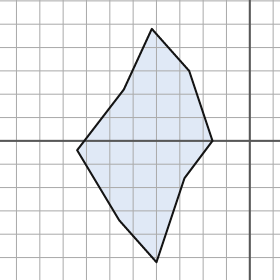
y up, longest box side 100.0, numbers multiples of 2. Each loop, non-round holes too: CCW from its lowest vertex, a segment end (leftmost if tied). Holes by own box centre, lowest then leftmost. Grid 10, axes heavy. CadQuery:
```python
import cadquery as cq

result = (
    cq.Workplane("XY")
    .moveTo(-40.0, -52.0)
    .lineTo(-28.0, -16.0)
    .lineTo(-16.0, 0.0)
    .lineTo(-26.0, 30.0)
    .lineTo(-42.0, 48.0)
    .lineTo(-54.0, 22.0)
    .lineTo(-74.0, -4.0)
    .lineTo(-56.0, -34.0)
    .close()
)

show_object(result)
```